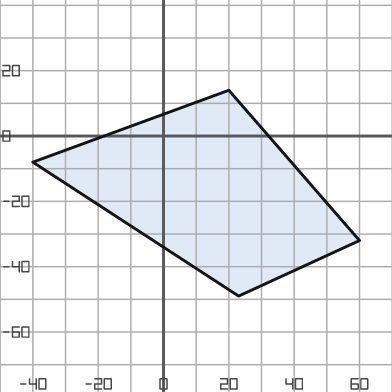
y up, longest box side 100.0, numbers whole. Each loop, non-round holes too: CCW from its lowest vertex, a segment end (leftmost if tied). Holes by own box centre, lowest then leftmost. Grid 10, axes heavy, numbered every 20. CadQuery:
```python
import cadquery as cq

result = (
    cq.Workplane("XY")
    .moveTo(23.0, -49.0)
    .lineTo(60.0, -32.0)
    .lineTo(20.0, 14.0)
    .lineTo(-40.0, -8.0)
    .close()
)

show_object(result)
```